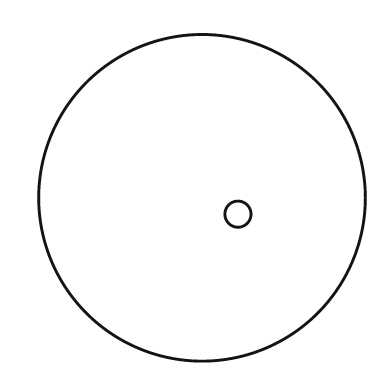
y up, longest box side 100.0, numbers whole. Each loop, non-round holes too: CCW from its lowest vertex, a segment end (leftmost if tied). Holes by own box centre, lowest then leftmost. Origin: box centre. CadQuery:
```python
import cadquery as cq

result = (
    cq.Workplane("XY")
    .moveTo(0.0, 0.0)
    .circle(50.0)
    .moveTo(11.0, -5.0)
    .circle(4.0)
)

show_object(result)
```